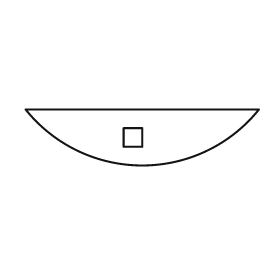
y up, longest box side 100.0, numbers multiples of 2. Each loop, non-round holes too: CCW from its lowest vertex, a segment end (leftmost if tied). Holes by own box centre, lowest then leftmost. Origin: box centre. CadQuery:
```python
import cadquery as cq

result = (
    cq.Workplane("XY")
    .moveTo(-50.0, 12.0)
    .threePointArc((0.0, -12.0), (50.0, 12.0))
    .close()
    .moveTo(-8.0, -4.0)
    .lineTo(0.0, -4.0)
    .lineTo(0.0, 4.0)
    .lineTo(-8.0, 4.0)
    .close()
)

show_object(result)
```